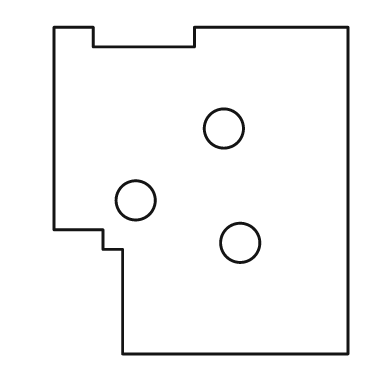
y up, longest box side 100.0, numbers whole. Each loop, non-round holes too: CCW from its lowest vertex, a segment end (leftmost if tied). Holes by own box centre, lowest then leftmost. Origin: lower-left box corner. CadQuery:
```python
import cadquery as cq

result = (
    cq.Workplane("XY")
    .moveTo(21.0, 0.0)
    .lineTo(90.0, 0.0)
    .lineTo(90.0, 100.0)
    .lineTo(43.0, 100.0)
    .lineTo(43.0, 94.0)
    .lineTo(12.0, 94.0)
    .lineTo(12.0, 100.0)
    .lineTo(0.0, 100.0)
    .lineTo(0.0, 38.0)
    .lineTo(15.0, 38.0)
    .lineTo(15.0, 32.0)
    .lineTo(21.0, 32.0)
    .close()
    .moveTo(57.0, 34.0)
    .circle(6.0)
    .moveTo(25.0, 47.0)
    .circle(6.0)
    .moveTo(52.0, 69.0)
    .circle(6.0)
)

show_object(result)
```